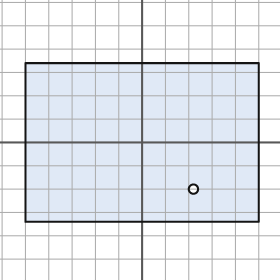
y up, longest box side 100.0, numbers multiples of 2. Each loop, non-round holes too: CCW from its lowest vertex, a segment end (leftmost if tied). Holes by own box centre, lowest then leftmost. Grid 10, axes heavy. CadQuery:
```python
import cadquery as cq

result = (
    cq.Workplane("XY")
    .moveTo(-50.0, -34.0)
    .lineTo(50.0, -34.0)
    .lineTo(50.0, 34.0)
    .lineTo(-50.0, 34.0)
    .close()
    .moveTo(22.0, -20.0)
    .circle(2.0)
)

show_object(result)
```